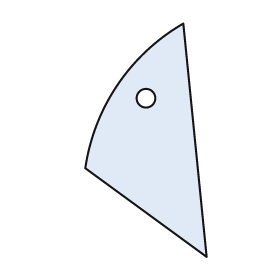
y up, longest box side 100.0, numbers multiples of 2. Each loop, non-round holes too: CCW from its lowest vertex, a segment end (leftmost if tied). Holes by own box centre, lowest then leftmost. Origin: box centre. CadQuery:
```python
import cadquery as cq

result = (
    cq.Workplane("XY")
    .moveTo(26.0, -50.0)
    .lineTo(16.0, 50.0)
    .threePointArc((-12.0, 24.0), (-26.0, -12.0))
    .close()
    .moveTo(0.0, 18.0)
    .circle(4.0)
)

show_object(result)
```